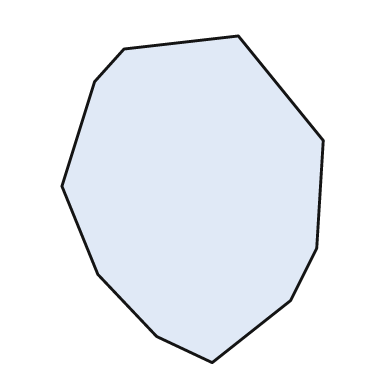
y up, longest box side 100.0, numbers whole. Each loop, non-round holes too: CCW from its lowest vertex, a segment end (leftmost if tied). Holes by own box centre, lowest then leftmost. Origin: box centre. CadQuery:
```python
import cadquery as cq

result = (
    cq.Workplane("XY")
    .moveTo(6.0, -50.0)
    .lineTo(30.0, -31.0)
    .lineTo(38.0, -15.0)
    .lineTo(40.0, 18.0)
    .lineTo(14.0, 50.0)
    .lineTo(-21.0, 46.0)
    .lineTo(-30.0, 36.0)
    .lineTo(-40.0, 4.0)
    .lineTo(-29.0, -23.0)
    .lineTo(-11.0, -42.0)
    .close()
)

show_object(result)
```